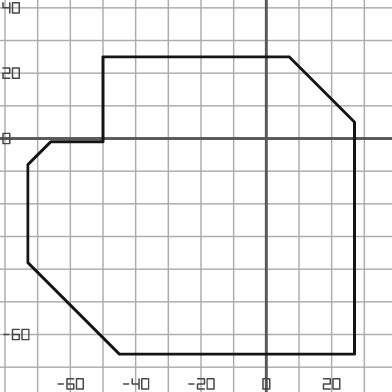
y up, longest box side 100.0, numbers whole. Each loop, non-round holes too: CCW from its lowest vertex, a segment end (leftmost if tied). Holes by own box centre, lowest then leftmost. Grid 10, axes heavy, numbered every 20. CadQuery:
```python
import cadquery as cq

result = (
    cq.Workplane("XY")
    .moveTo(-45.0, -66.0)
    .lineTo(27.0, -66.0)
    .lineTo(27.0, 5.0)
    .lineTo(7.0, 25.0)
    .lineTo(-50.0, 25.0)
    .lineTo(-50.0, -1.0)
    .lineTo(-66.0, -1.0)
    .lineTo(-73.0, -8.0)
    .lineTo(-73.0, -38.0)
    .close()
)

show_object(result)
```